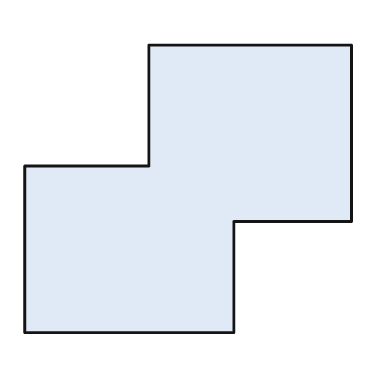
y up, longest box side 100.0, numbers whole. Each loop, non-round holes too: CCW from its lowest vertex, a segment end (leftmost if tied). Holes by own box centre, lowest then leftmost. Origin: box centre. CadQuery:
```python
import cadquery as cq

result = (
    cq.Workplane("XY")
    .moveTo(-50.0, -44.0)
    .lineTo(14.0, -44.0)
    .lineTo(14.0, -10.0)
    .lineTo(50.0, -10.0)
    .lineTo(50.0, 44.0)
    .lineTo(-12.0, 44.0)
    .lineTo(-12.0, 7.0)
    .lineTo(-50.0, 7.0)
    .close()
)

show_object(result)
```